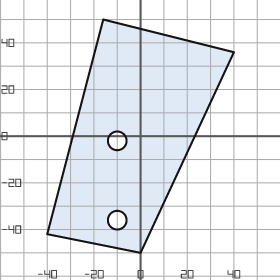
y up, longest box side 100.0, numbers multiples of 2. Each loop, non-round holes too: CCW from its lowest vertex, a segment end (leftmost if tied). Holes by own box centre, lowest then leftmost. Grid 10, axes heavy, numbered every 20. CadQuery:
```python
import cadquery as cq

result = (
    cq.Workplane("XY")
    .moveTo(0.0, -50.0)
    .lineTo(40.0, 36.0)
    .lineTo(-16.0, 50.0)
    .lineTo(-40.0, -42.0)
    .close()
    .moveTo(-10.0, -36.0)
    .circle(4.0)
    .moveTo(-10.0, -2.0)
    .circle(4.0)
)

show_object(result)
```